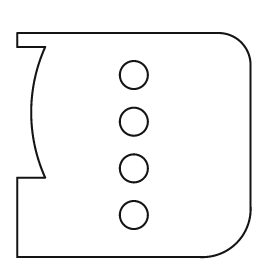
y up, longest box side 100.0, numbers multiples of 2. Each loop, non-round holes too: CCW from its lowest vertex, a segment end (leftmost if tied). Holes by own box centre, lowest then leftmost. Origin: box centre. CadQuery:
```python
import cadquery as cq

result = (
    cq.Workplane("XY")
    .moveTo(-50.0, -48.0)
    .lineTo(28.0, -48.0)
    .threePointArc((44.0, -42.0), (50.0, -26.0))
    .lineTo(50.0, 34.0)
    .threePointArc((46.0, 44.0), (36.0, 48.0))
    .lineTo(-50.0, 48.0)
    .lineTo(-50.0, 42.0)
    .lineTo(-38.0, 42.0)
    .threePointArc((-44.0, 14.0), (-38.0, -14.0))
    .lineTo(-50.0, -14.0)
    .close()
    .moveTo(0.0, -30.0)
    .circle(6.0)
    .moveTo(0.0, -10.0)
    .circle(6.0)
    .moveTo(0.0, 10.0)
    .circle(6.0)
    .moveTo(0.0, 30.0)
    .circle(6.0)
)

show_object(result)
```